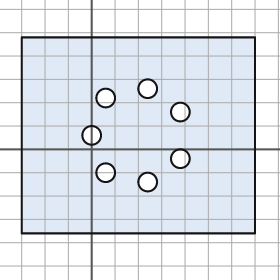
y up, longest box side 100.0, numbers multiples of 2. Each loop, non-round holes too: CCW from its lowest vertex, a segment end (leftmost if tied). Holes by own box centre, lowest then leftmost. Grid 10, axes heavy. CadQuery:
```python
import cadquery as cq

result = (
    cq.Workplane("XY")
    .moveTo(-30.0, -36.0)
    .lineTo(70.0, -36.0)
    .lineTo(70.0, 48.0)
    .lineTo(-30.0, 48.0)
    .close()
    .moveTo(24.0, -14.0)
    .circle(4.0)
    .moveTo(6.0, -10.0)
    .circle(4.0)
    .moveTo(38.0, -4.0)
    .circle(4.0)
    .moveTo(0.0, 6.0)
    .circle(4.0)
    .moveTo(38.0, 16.0)
    .circle(4.0)
    .moveTo(6.0, 22.0)
    .circle(4.0)
    .moveTo(24.0, 26.0)
    .circle(4.0)
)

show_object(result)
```